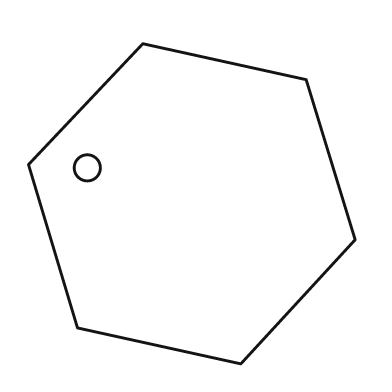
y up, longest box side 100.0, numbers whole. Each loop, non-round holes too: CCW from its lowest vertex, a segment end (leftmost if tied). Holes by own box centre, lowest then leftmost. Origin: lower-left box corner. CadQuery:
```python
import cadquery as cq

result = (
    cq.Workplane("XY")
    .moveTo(65.0, 0.0)
    .lineTo(100.0, 38.0)
    .lineTo(85.0, 87.0)
    .lineTo(35.0, 98.0)
    .lineTo(0.0, 61.0)
    .lineTo(15.0, 11.0)
    .close()
    .moveTo(18.0, 60.0)
    .circle(4.0)
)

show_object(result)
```